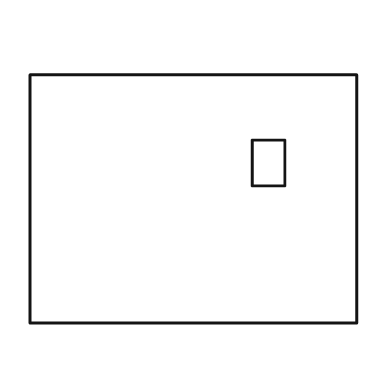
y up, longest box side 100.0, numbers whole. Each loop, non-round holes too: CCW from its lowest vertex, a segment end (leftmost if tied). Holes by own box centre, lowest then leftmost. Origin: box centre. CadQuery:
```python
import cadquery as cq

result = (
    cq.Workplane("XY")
    .moveTo(-50.0, -38.0)
    .lineTo(50.0, -38.0)
    .lineTo(50.0, 38.0)
    .lineTo(-50.0, 38.0)
    .close()
    .moveTo(18.0, 4.0)
    .lineTo(28.0, 4.0)
    .lineTo(28.0, 18.0)
    .lineTo(18.0, 18.0)
    .close()
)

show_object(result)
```